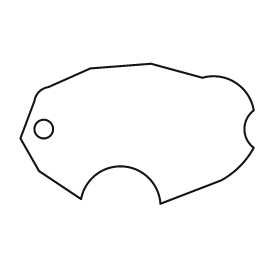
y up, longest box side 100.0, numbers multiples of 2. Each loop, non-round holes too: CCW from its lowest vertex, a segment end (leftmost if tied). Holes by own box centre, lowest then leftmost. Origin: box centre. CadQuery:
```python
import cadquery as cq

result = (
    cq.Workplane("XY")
    .moveTo(10.0, -30.0)
    .lineTo(36.0, -20.0)
    .threePointArc((44.0, -14.0), (50.0, -6.0))
    .threePointArc((46.0, 2.0), (50.0, 10.0))
    .threePointArc((42.0, 22.0), (28.0, 24.0))
    .lineTo(6.0, 30.0)
    .lineTo(-20.0, 28.0)
    .lineTo(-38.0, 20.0)
    .threePointArc((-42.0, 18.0), (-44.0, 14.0))
    .lineTo(-50.0, -2.0)
    .lineTo(-42.0, -16.0)
    .lineTo(-24.0, -28.0)
    .threePointArc((-6.0, -14.0), (10.0, -30.0))
    .close()
    .moveTo(-40.0, 2.0)
    .circle(4.0)
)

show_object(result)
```